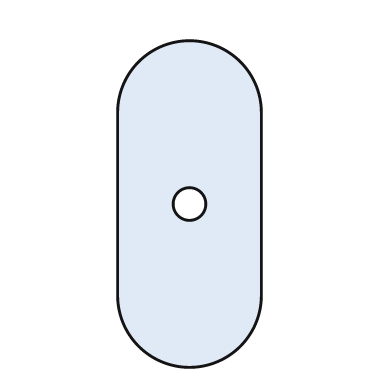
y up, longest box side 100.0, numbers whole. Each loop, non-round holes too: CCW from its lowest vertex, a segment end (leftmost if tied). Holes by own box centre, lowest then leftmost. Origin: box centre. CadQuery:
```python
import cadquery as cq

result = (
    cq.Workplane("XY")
    .moveTo(-22.0, -28.0)
    .threePointArc((0.0, -50.0), (22.0, -28.0))
    .lineTo(22.0, 28.0)
    .threePointArc((0.0, 50.0), (-22.0, 28.0))
    .close()
    .moveTo(0.0, 0.0)
    .circle(5.0)
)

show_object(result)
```